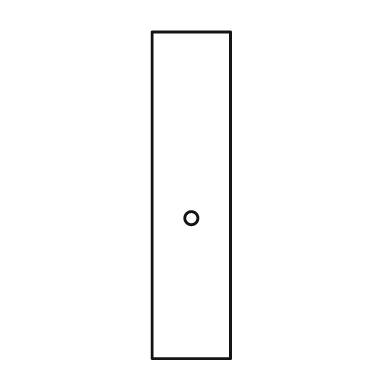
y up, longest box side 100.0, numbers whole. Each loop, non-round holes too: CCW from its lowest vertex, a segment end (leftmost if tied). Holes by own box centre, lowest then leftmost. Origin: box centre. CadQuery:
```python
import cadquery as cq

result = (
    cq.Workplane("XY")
    .moveTo(-12.0, -50.0)
    .lineTo(12.0, -50.0)
    .lineTo(12.0, 50.0)
    .lineTo(-12.0, 50.0)
    .close()
    .moveTo(0.0, -7.0)
    .circle(2.0)
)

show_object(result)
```